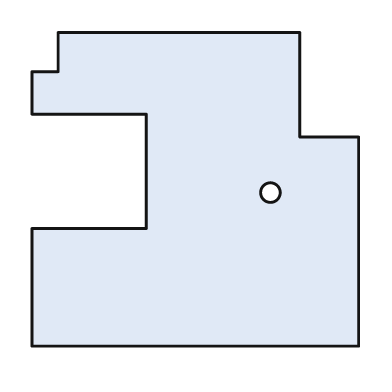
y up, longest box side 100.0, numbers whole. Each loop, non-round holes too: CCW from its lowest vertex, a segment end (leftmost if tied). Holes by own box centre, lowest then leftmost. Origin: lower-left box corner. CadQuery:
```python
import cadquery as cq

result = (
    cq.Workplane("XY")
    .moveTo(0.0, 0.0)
    .lineTo(100.0, 0.0)
    .lineTo(100.0, 64.0)
    .lineTo(82.0, 64.0)
    .lineTo(82.0, 96.0)
    .lineTo(8.0, 96.0)
    .lineTo(8.0, 84.0)
    .lineTo(0.0, 84.0)
    .lineTo(0.0, 71.0)
    .lineTo(35.0, 71.0)
    .lineTo(35.0, 36.0)
    .lineTo(0.0, 36.0)
    .close()
    .moveTo(73.0, 47.0)
    .circle(3.0)
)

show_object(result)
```